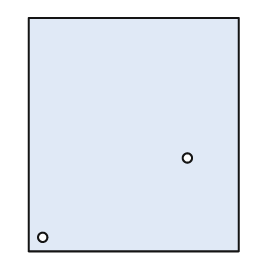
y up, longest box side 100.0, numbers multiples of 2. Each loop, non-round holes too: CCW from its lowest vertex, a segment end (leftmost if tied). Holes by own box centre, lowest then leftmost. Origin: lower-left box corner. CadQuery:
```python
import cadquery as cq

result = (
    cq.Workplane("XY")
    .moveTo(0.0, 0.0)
    .lineTo(90.0, 0.0)
    .lineTo(90.0, 100.0)
    .lineTo(0.0, 100.0)
    .close()
    .moveTo(6.0, 6.0)
    .circle(2.0)
    .moveTo(68.0, 40.0)
    .circle(2.0)
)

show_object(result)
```